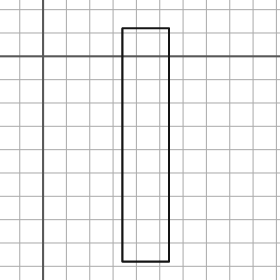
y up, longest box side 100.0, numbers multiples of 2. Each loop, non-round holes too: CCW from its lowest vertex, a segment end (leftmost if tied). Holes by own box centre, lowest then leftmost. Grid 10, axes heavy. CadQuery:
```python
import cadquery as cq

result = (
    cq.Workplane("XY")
    .moveTo(34.0, -88.0)
    .lineTo(54.0, -88.0)
    .lineTo(54.0, 12.0)
    .lineTo(34.0, 12.0)
    .close()
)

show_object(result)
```